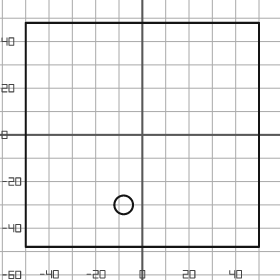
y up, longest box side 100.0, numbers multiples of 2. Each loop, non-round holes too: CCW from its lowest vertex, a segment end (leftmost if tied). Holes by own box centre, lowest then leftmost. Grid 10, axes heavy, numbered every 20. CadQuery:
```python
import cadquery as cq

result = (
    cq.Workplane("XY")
    .moveTo(-50.0, -48.0)
    .lineTo(50.0, -48.0)
    .lineTo(50.0, 48.0)
    .lineTo(-50.0, 48.0)
    .close()
    .moveTo(-8.0, -30.0)
    .circle(4.0)
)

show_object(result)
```